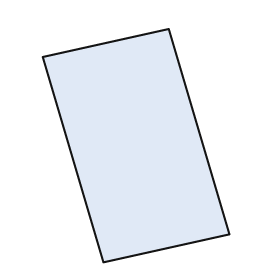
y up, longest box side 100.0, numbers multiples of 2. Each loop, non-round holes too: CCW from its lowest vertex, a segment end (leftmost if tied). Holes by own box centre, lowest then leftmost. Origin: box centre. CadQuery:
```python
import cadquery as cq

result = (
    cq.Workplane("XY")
    .moveTo(-14.0, -50.0)
    .lineTo(40.0, -38.0)
    .lineTo(14.0, 50.0)
    .lineTo(-40.0, 38.0)
    .close()
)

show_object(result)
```